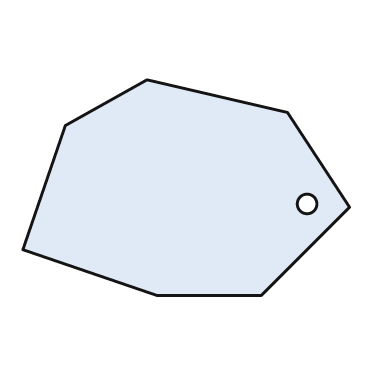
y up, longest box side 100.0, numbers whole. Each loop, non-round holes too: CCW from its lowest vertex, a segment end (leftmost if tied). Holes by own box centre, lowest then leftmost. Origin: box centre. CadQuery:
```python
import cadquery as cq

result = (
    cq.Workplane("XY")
    .moveTo(-9.0, -33.0)
    .lineTo(23.0, -33.0)
    .lineTo(50.0, -6.0)
    .lineTo(31.0, 23.0)
    .lineTo(-12.0, 33.0)
    .lineTo(-37.0, 19.0)
    .lineTo(-50.0, -19.0)
    .close()
    .moveTo(37.0, -5.0)
    .circle(3.0)
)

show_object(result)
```